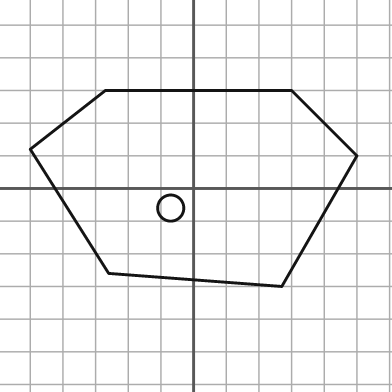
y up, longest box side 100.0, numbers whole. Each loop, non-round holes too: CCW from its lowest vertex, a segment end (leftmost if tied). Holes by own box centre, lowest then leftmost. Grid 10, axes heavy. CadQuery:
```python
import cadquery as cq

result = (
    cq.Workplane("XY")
    .moveTo(27.0, -30.0)
    .lineTo(50.0, 10.0)
    .lineTo(30.0, 30.0)
    .lineTo(-27.0, 30.0)
    .lineTo(-50.0, 12.0)
    .lineTo(-26.0, -26.0)
    .close()
    .moveTo(-7.0, -6.0)
    .circle(4.0)
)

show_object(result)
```